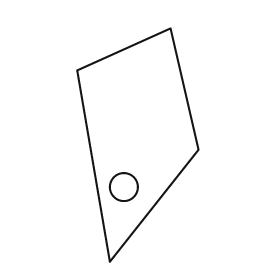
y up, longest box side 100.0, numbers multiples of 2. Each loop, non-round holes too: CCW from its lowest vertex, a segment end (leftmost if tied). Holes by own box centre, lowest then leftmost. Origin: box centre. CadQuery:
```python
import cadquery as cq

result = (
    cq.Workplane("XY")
    .moveTo(-12.0, -50.0)
    .lineTo(26.0, -2.0)
    .lineTo(14.0, 50.0)
    .lineTo(-26.0, 32.0)
    .close()
    .moveTo(-6.0, -18.0)
    .circle(6.0)
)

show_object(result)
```